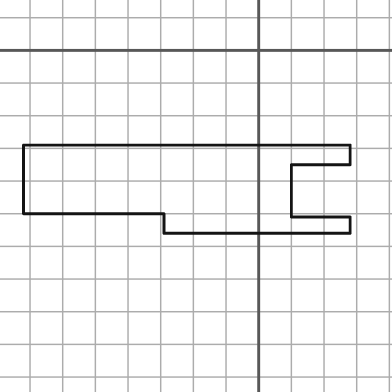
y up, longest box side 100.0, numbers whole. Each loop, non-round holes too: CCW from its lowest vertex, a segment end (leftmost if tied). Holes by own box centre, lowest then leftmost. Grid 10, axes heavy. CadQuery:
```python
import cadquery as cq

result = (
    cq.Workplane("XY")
    .moveTo(-29.0, -56.0)
    .lineTo(28.0, -56.0)
    .lineTo(28.0, -51.0)
    .lineTo(10.0, -51.0)
    .lineTo(10.0, -35.0)
    .lineTo(28.0, -35.0)
    .lineTo(28.0, -29.0)
    .lineTo(-72.0, -29.0)
    .lineTo(-72.0, -50.0)
    .lineTo(-29.0, -50.0)
    .close()
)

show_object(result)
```